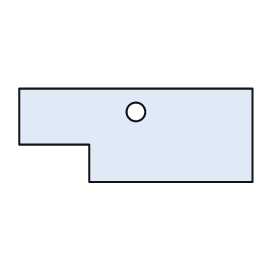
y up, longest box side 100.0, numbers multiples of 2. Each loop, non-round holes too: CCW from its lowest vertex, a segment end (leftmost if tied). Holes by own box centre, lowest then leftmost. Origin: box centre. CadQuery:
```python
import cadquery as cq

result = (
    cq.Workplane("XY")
    .moveTo(-20.0, -20.0)
    .lineTo(50.0, -20.0)
    .lineTo(50.0, 20.0)
    .lineTo(-50.0, 20.0)
    .lineTo(-50.0, -4.0)
    .lineTo(-20.0, -4.0)
    .close()
    .moveTo(0.0, 10.0)
    .circle(4.0)
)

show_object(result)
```